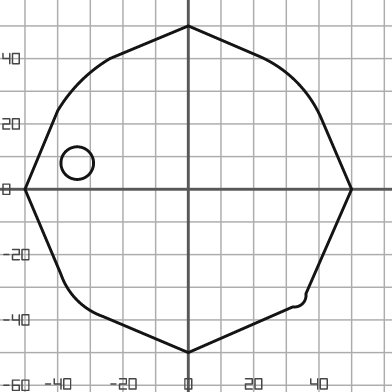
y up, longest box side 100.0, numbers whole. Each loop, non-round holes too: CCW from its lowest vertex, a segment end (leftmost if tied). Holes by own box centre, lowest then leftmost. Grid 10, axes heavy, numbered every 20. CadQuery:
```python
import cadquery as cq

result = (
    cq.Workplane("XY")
    .moveTo(0.0, -50.0)
    .lineTo(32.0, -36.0)
    .threePointArc((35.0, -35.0), (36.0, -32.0))
    .lineTo(50.0, 0.0)
    .lineTo(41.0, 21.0)
    .threePointArc((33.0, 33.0), (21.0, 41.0))
    .lineTo(0.0, 50.0)
    .lineTo(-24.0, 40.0)
    .threePointArc((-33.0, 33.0), (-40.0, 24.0))
    .lineTo(-50.0, 0.0)
    .lineTo(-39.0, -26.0)
    .threePointArc((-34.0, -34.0), (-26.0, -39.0))
    .close()
    .moveTo(-34.0, 8.0)
    .circle(5.0)
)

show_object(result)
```